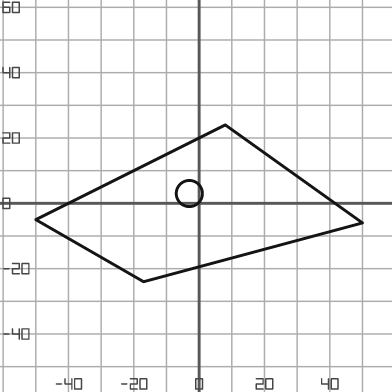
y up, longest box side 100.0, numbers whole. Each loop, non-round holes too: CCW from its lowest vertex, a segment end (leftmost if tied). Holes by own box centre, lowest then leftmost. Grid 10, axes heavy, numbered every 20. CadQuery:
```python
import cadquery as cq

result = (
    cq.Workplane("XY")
    .moveTo(-17.0, -24.0)
    .lineTo(50.0, -6.0)
    .lineTo(8.0, 24.0)
    .lineTo(-50.0, -5.0)
    .close()
    .moveTo(-3.0, 3.0)
    .circle(4.0)
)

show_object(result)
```